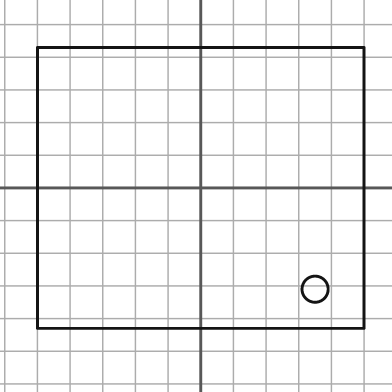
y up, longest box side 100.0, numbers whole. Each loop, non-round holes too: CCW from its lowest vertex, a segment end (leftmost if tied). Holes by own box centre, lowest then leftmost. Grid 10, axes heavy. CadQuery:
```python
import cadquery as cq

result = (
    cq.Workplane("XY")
    .moveTo(-50.0, -43.0)
    .lineTo(50.0, -43.0)
    .lineTo(50.0, 43.0)
    .lineTo(-50.0, 43.0)
    .close()
    .moveTo(35.0, -31.0)
    .circle(4.0)
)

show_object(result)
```